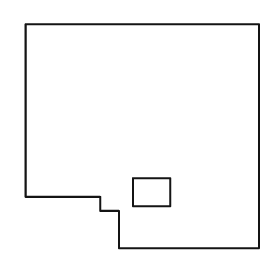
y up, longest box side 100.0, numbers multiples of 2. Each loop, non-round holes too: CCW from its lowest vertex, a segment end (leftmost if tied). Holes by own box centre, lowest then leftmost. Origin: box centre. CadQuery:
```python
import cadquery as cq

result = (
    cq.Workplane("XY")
    .moveTo(-10.0, -48.0)
    .lineTo(50.0, -48.0)
    .lineTo(50.0, 48.0)
    .lineTo(-50.0, 48.0)
    .lineTo(-50.0, -26.0)
    .lineTo(-18.0, -26.0)
    .lineTo(-18.0, -32.0)
    .lineTo(-10.0, -32.0)
    .close()
    .moveTo(-4.0, -30.0)
    .lineTo(12.0, -30.0)
    .lineTo(12.0, -18.0)
    .lineTo(-4.0, -18.0)
    .close()
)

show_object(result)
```